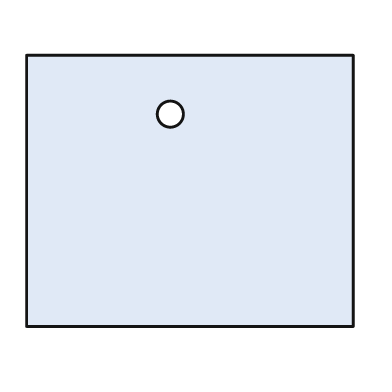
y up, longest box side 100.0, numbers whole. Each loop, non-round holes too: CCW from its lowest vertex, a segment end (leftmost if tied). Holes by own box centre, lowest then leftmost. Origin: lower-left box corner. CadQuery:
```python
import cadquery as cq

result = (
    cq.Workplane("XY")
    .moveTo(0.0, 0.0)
    .lineTo(100.0, 0.0)
    .lineTo(100.0, 83.0)
    .lineTo(0.0, 83.0)
    .close()
    .moveTo(44.0, 65.0)
    .circle(4.0)
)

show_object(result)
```